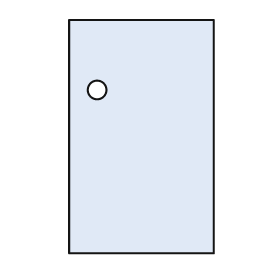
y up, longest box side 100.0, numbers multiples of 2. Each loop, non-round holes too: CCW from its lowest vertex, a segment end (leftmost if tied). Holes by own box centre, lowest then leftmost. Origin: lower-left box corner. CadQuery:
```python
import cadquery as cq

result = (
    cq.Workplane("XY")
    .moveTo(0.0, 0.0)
    .lineTo(62.0, 0.0)
    .lineTo(62.0, 100.0)
    .lineTo(0.0, 100.0)
    .close()
    .moveTo(12.0, 70.0)
    .circle(4.0)
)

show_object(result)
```